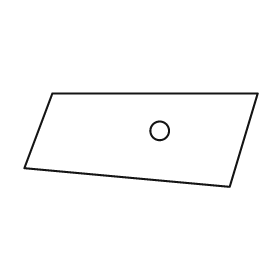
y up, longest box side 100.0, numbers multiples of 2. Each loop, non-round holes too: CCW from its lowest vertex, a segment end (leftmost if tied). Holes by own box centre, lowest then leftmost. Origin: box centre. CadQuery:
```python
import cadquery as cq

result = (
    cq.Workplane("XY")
    .moveTo(38.0, -20.0)
    .lineTo(50.0, 20.0)
    .lineTo(-38.0, 20.0)
    .lineTo(-50.0, -12.0)
    .close()
    .moveTo(8.0, 4.0)
    .circle(4.0)
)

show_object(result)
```